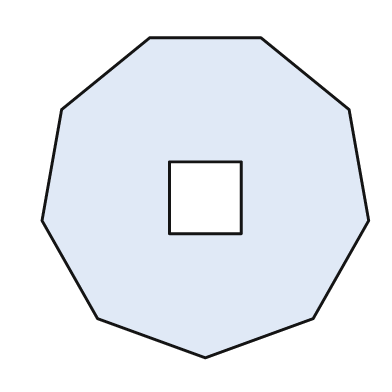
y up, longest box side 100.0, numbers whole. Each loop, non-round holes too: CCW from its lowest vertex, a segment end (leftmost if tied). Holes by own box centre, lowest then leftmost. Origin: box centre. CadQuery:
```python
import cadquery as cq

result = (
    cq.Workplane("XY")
    .moveTo(0.0, -49.0)
    .lineTo(33.0, -37.0)
    .lineTo(50.0, -7.0)
    .lineTo(44.0, 27.0)
    .lineTo(17.0, 49.0)
    .lineTo(-17.0, 49.0)
    .lineTo(-44.0, 27.0)
    .lineTo(-50.0, -7.0)
    .lineTo(-33.0, -37.0)
    .close()
    .moveTo(-11.0, -11.0)
    .lineTo(11.0, -11.0)
    .lineTo(11.0, 11.0)
    .lineTo(-11.0, 11.0)
    .close()
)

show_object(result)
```